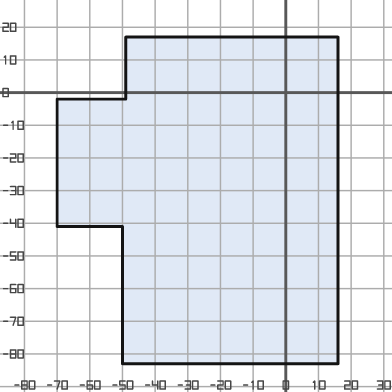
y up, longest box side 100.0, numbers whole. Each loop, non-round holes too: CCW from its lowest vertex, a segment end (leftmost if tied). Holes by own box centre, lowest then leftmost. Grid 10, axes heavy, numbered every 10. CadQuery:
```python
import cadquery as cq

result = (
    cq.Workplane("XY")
    .moveTo(-50.0, -83.0)
    .lineTo(16.0, -83.0)
    .lineTo(16.0, 17.0)
    .lineTo(-49.0, 17.0)
    .lineTo(-49.0, -2.0)
    .lineTo(-70.0, -2.0)
    .lineTo(-70.0, -41.0)
    .lineTo(-50.0, -41.0)
    .close()
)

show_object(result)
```